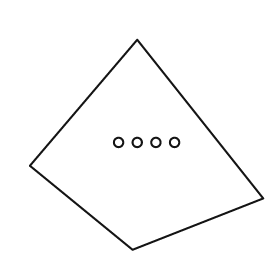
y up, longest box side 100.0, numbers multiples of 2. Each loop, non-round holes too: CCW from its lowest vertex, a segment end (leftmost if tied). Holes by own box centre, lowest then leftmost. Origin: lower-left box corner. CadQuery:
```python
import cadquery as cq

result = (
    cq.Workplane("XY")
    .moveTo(44.0, 0.0)
    .lineTo(100.0, 22.0)
    .lineTo(46.0, 90.0)
    .lineTo(0.0, 36.0)
    .close()
    .moveTo(38.0, 46.0)
    .circle(2.0)
    .moveTo(46.0, 46.0)
    .circle(2.0)
    .moveTo(54.0, 46.0)
    .circle(2.0)
    .moveTo(62.0, 46.0)
    .circle(2.0)
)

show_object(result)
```